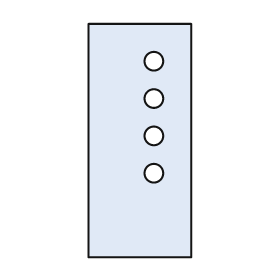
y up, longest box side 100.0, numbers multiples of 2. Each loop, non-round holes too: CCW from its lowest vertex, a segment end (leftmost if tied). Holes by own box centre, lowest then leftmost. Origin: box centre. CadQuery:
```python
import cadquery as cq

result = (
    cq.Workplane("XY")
    .moveTo(-22.0, -50.0)
    .lineTo(22.0, -50.0)
    .lineTo(22.0, 50.0)
    .lineTo(-22.0, 50.0)
    .close()
    .moveTo(6.0, -14.0)
    .circle(4.0)
    .moveTo(6.0, 2.0)
    .circle(4.0)
    .moveTo(6.0, 18.0)
    .circle(4.0)
    .moveTo(6.0, 34.0)
    .circle(4.0)
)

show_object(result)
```